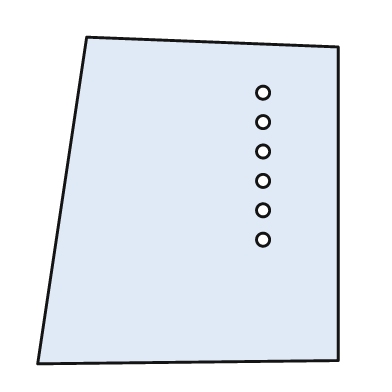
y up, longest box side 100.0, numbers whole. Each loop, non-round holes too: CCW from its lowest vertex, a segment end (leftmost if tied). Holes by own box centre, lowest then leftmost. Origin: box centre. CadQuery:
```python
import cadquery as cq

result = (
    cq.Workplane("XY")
    .moveTo(-46.0, -50.0)
    .lineTo(46.0, -49.0)
    .lineTo(46.0, 47.0)
    .lineTo(-31.0, 50.0)
    .close()
    .moveTo(23.0, -12.0)
    .circle(2.0)
    .moveTo(23.0, -3.0)
    .circle(2.0)
    .moveTo(23.0, 6.0)
    .circle(2.0)
    .moveTo(23.0, 15.0)
    .circle(2.0)
    .moveTo(23.0, 24.0)
    .circle(2.0)
    .moveTo(23.0, 33.0)
    .circle(2.0)
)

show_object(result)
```